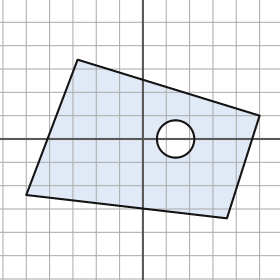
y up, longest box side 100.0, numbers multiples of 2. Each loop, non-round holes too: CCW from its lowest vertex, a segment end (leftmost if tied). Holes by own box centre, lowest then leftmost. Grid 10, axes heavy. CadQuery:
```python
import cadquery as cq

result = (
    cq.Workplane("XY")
    .moveTo(36.0, -34.0)
    .lineTo(50.0, 10.0)
    .lineTo(-28.0, 34.0)
    .lineTo(-50.0, -24.0)
    .close()
    .moveTo(14.0, 0.0)
    .circle(8.0)
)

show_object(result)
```